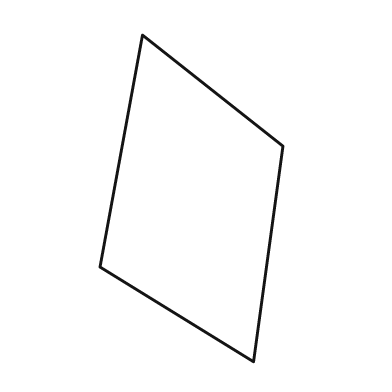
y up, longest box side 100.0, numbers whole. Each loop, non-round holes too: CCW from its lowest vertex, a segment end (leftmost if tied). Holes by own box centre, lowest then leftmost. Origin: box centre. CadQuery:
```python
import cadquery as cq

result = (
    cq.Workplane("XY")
    .moveTo(19.0, -50.0)
    .lineTo(28.0, 16.0)
    .lineTo(-15.0, 50.0)
    .lineTo(-28.0, -21.0)
    .close()
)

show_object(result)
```